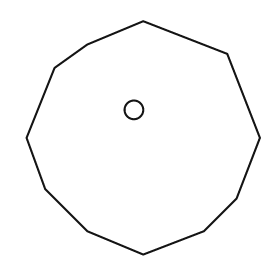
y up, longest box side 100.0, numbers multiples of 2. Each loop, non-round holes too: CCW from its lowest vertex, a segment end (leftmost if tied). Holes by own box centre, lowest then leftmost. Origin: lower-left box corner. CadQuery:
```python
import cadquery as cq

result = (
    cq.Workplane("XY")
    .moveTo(50.0, 0.0)
    .lineTo(76.0, 10.0)
    .lineTo(90.0, 24.0)
    .lineTo(100.0, 50.0)
    .lineTo(86.0, 86.0)
    .lineTo(50.0, 100.0)
    .lineTo(26.0, 90.0)
    .lineTo(12.0, 80.0)
    .lineTo(0.0, 50.0)
    .lineTo(8.0, 28.0)
    .lineTo(26.0, 10.0)
    .close()
    .moveTo(46.0, 62.0)
    .circle(4.0)
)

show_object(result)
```